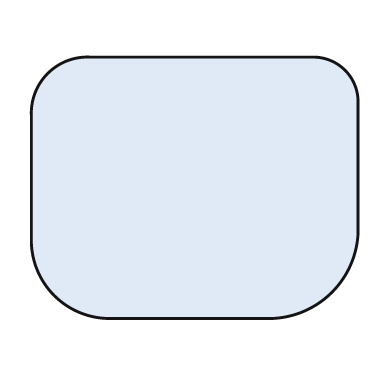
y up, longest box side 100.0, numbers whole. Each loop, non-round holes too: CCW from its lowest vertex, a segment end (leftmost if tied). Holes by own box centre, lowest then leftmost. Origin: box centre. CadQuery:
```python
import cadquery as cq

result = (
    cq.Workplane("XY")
    .moveTo(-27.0, -40.0)
    .lineTo(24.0, -40.0)
    .threePointArc((42.0, -32.0), (50.0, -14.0))
    .lineTo(50.0, 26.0)
    .threePointArc((46.0, 36.0), (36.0, 40.0))
    .lineTo(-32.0, 40.0)
    .threePointArc((-45.0, 35.0), (-50.0, 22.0))
    .lineTo(-50.0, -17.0)
    .threePointArc((-43.0, -33.0), (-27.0, -40.0))
    .close()
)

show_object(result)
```